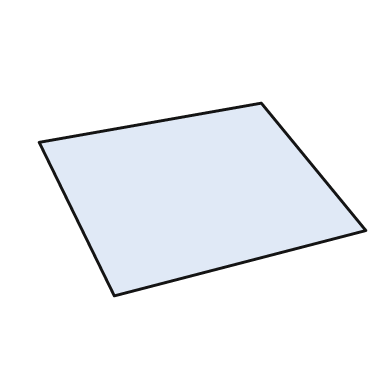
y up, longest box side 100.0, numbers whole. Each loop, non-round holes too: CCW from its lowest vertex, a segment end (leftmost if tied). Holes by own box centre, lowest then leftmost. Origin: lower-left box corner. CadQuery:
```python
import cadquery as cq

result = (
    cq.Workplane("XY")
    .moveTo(23.0, 0.0)
    .lineTo(100.0, 20.0)
    .lineTo(68.0, 59.0)
    .lineTo(0.0, 47.0)
    .close()
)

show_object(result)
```